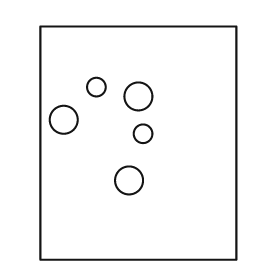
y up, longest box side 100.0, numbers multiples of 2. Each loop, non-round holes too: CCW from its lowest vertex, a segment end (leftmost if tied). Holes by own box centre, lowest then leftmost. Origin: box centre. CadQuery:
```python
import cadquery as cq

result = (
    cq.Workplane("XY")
    .moveTo(-42.0, -50.0)
    .lineTo(42.0, -50.0)
    .lineTo(42.0, 50.0)
    .lineTo(-42.0, 50.0)
    .close()
    .moveTo(-4.0, -16.0)
    .circle(6.0)
    .moveTo(2.0, 4.0)
    .circle(4.0)
    .moveTo(-32.0, 10.0)
    .circle(6.0)
    .moveTo(0.0, 20.0)
    .circle(6.0)
    .moveTo(-18.0, 24.0)
    .circle(4.0)
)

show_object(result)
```